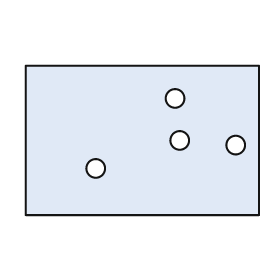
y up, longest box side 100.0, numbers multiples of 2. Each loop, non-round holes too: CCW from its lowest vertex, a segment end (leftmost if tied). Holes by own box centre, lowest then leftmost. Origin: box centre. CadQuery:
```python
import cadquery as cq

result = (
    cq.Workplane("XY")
    .moveTo(-50.0, -32.0)
    .lineTo(50.0, -32.0)
    .lineTo(50.0, 32.0)
    .lineTo(-50.0, 32.0)
    .close()
    .moveTo(-20.0, -12.0)
    .circle(4.0)
    .moveTo(40.0, -2.0)
    .circle(4.0)
    .moveTo(16.0, 0.0)
    .circle(4.0)
    .moveTo(14.0, 18.0)
    .circle(4.0)
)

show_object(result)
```